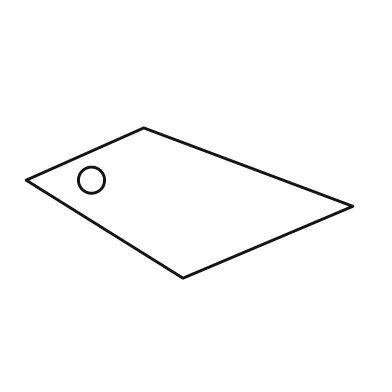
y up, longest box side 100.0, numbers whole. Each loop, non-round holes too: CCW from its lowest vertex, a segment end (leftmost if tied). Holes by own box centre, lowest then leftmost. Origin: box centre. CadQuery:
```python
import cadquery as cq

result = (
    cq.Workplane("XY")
    .moveTo(-2.0, -23.0)
    .lineTo(50.0, -1.0)
    .lineTo(-14.0, 23.0)
    .lineTo(-50.0, 7.0)
    .close()
    .moveTo(-30.0, 7.0)
    .circle(4.0)
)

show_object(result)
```